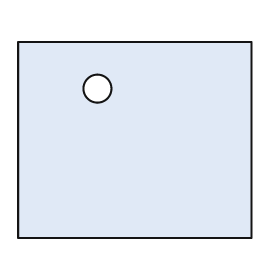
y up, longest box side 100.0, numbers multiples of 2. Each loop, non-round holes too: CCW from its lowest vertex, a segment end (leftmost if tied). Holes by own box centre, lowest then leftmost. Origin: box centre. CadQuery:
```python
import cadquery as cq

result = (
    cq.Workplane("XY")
    .moveTo(-50.0, -42.0)
    .lineTo(50.0, -42.0)
    .lineTo(50.0, 42.0)
    .lineTo(-50.0, 42.0)
    .close()
    .moveTo(-16.0, 22.0)
    .circle(6.0)
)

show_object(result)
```